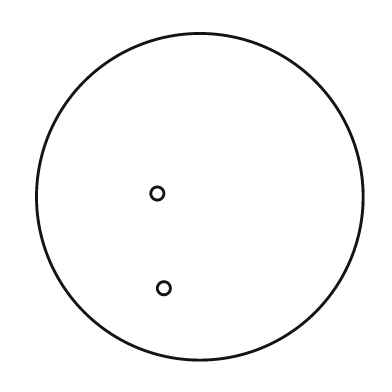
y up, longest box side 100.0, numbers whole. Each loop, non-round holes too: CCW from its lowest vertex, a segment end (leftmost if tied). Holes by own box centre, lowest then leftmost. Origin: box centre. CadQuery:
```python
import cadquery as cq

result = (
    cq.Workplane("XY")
    .moveTo(0.0, 0.0)
    .circle(50.0)
    .moveTo(-11.0, -28.0)
    .circle(2.0)
    .moveTo(-13.0, 1.0)
    .circle(2.0)
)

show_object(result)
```